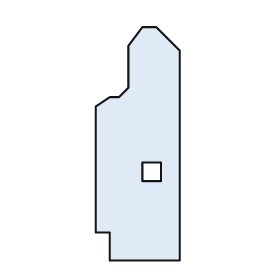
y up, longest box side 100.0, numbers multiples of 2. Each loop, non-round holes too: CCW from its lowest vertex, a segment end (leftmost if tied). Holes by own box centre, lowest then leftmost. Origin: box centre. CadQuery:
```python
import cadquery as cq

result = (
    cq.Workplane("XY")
    .moveTo(-12.0, -50.0)
    .lineTo(18.0, -50.0)
    .lineTo(18.0, 40.0)
    .lineTo(8.0, 50.0)
    .lineTo(2.0, 50.0)
    .lineTo(-4.0, 42.0)
    .lineTo(-4.0, 24.0)
    .lineTo(-8.0, 20.0)
    .lineTo(-12.0, 20.0)
    .lineTo(-18.0, 16.0)
    .lineTo(-18.0, -38.0)
    .lineTo(-12.0, -38.0)
    .close()
    .moveTo(2.0, -16.0)
    .lineTo(10.0, -16.0)
    .lineTo(10.0, -8.0)
    .lineTo(2.0, -8.0)
    .close()
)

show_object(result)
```